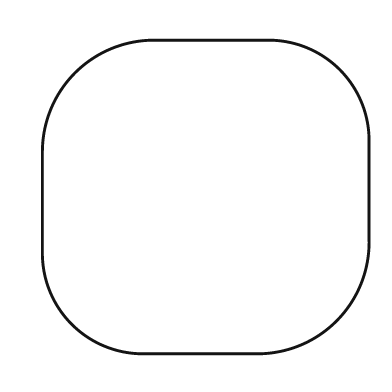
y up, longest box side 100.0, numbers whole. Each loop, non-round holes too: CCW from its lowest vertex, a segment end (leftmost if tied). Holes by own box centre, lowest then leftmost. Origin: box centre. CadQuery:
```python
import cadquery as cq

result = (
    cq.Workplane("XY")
    .moveTo(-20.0, -48.0)
    .lineTo(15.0, -48.0)
    .threePointArc((40.0, -38.0), (50.0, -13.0))
    .lineTo(50.0, 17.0)
    .threePointArc((41.0, 39.0), (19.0, 48.0))
    .lineTo(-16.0, 48.0)
    .threePointArc((-40.0, 38.0), (-50.0, 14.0))
    .lineTo(-50.0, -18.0)
    .threePointArc((-41.0, -39.0), (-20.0, -48.0))
    .close()
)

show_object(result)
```